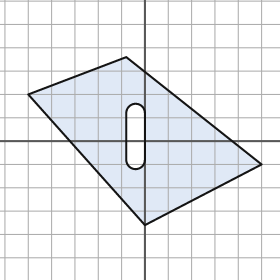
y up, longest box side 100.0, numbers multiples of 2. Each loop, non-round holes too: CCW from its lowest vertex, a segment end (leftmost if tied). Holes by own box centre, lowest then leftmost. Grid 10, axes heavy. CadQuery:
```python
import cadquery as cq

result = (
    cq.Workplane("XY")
    .moveTo(0.0, -36.0)
    .lineTo(50.0, -10.0)
    .lineTo(-8.0, 36.0)
    .lineTo(-50.0, 20.0)
    .close()
    .moveTo(-8.0, -8.0)
    .threePointArc((-4.0, -12.0), (0.0, -8.0))
    .lineTo(0.0, 12.0)
    .threePointArc((-4.0, 16.0), (-8.0, 12.0))
    .close()
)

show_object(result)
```